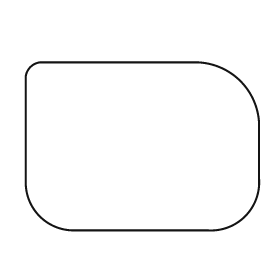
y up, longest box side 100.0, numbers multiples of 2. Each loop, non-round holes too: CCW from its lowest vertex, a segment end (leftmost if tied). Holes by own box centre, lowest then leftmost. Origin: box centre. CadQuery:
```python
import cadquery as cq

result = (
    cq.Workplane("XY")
    .moveTo(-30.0, -36.0)
    .lineTo(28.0, -36.0)
    .threePointArc((44.0, -30.0), (50.0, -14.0))
    .lineTo(50.0, 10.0)
    .threePointArc((42.0, 28.0), (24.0, 36.0))
    .lineTo(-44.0, 36.0)
    .threePointArc((-48.0, 34.0), (-50.0, 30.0))
    .lineTo(-50.0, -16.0)
    .threePointArc((-44.0, -30.0), (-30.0, -36.0))
    .close()
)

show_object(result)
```